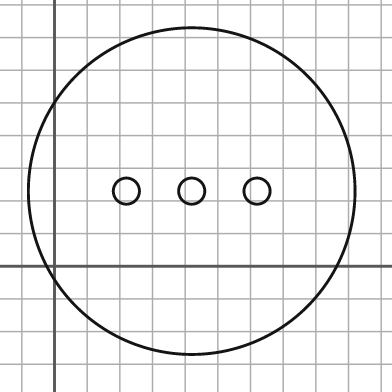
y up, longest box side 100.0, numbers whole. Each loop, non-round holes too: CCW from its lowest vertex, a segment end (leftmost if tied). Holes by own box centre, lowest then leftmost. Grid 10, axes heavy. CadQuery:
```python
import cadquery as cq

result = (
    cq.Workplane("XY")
    .moveTo(42.0, 23.0)
    .circle(50.0)
    .moveTo(22.0, 23.0)
    .circle(4.0)
    .moveTo(42.0, 23.0)
    .circle(4.0)
    .moveTo(62.0, 23.0)
    .circle(4.0)
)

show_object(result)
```